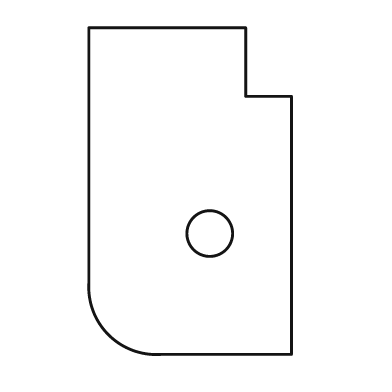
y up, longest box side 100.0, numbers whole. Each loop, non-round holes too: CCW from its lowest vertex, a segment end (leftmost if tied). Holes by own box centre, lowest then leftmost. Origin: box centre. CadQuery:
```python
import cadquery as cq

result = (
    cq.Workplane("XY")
    .moveTo(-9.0, -50.0)
    .lineTo(31.0, -50.0)
    .lineTo(31.0, 29.0)
    .lineTo(17.0, 29.0)
    .lineTo(17.0, 50.0)
    .lineTo(-31.0, 50.0)
    .lineTo(-31.0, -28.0)
    .threePointArc((-25.0, -44.0), (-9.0, -50.0))
    .close()
    .moveTo(6.0, -13.0)
    .circle(7.0)
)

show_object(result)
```